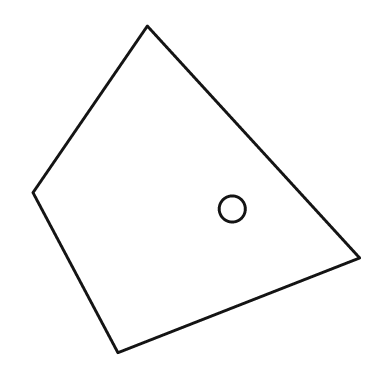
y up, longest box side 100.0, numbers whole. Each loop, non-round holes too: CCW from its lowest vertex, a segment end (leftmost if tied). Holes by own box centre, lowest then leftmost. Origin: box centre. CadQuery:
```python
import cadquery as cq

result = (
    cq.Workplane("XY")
    .moveTo(-24.0, -50.0)
    .lineTo(50.0, -21.0)
    .lineTo(-15.0, 50.0)
    .lineTo(-50.0, -1.0)
    .close()
    .moveTo(11.0, -6.0)
    .circle(4.0)
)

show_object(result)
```